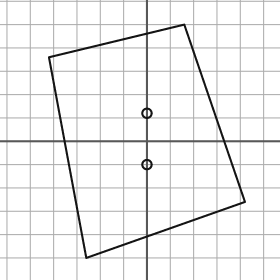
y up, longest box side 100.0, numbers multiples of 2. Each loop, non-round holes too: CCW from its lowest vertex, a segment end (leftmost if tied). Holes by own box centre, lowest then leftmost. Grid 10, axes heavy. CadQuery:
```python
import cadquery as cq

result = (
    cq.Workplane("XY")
    .moveTo(-26.0, -50.0)
    .lineTo(42.0, -26.0)
    .lineTo(16.0, 50.0)
    .lineTo(-42.0, 36.0)
    .close()
    .moveTo(0.0, -10.0)
    .circle(2.0)
    .moveTo(0.0, 12.0)
    .circle(2.0)
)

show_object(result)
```